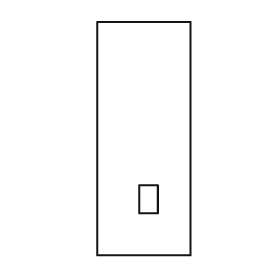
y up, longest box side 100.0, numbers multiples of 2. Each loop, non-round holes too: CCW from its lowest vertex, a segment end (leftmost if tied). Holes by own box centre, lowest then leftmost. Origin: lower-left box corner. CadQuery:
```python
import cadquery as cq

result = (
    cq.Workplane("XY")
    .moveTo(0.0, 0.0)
    .lineTo(40.0, 0.0)
    .lineTo(40.0, 100.0)
    .lineTo(0.0, 100.0)
    .close()
    .moveTo(18.0, 18.0)
    .lineTo(26.0, 18.0)
    .lineTo(26.0, 30.0)
    .lineTo(18.0, 30.0)
    .close()
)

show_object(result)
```